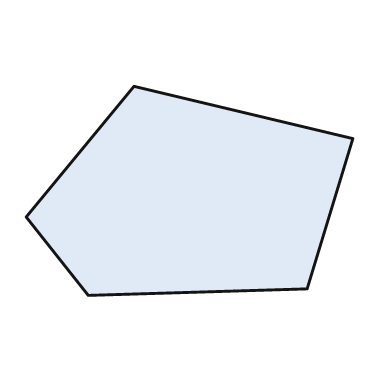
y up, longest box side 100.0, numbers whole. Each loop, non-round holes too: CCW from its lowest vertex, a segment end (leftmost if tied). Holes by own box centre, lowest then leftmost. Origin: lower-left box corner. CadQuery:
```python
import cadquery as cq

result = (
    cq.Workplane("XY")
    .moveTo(19.0, 0.0)
    .lineTo(86.0, 2.0)
    .lineTo(100.0, 48.0)
    .lineTo(33.0, 64.0)
    .lineTo(0.0, 24.0)
    .close()
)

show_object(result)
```